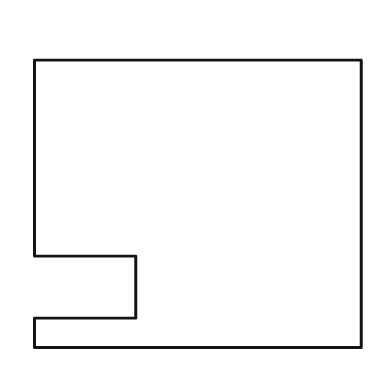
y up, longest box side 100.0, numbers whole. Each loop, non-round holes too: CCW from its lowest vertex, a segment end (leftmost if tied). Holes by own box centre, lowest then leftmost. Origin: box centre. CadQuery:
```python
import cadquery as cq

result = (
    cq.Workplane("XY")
    .moveTo(-50.0, -44.0)
    .lineTo(50.0, -44.0)
    .lineTo(50.0, 44.0)
    .lineTo(-50.0, 44.0)
    .lineTo(-50.0, -16.0)
    .lineTo(-19.0, -16.0)
    .lineTo(-19.0, -35.0)
    .lineTo(-50.0, -35.0)
    .close()
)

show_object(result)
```